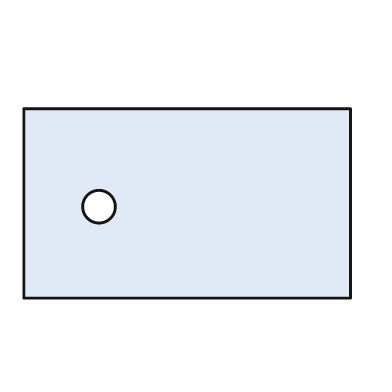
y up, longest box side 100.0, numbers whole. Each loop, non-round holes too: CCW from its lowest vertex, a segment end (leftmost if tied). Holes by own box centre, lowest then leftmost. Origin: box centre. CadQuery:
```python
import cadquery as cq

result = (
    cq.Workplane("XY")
    .moveTo(-50.0, -29.0)
    .lineTo(50.0, -29.0)
    .lineTo(50.0, 29.0)
    .lineTo(-50.0, 29.0)
    .close()
    .moveTo(-27.0, -1.0)
    .circle(5.0)
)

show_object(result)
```